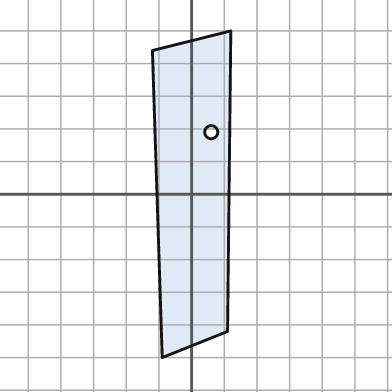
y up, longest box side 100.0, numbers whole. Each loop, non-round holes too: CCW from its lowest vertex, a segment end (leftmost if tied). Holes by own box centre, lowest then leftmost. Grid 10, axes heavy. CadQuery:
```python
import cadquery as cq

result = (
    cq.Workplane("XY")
    .moveTo(-9.0, -50.0)
    .lineTo(11.0, -42.0)
    .lineTo(12.0, 50.0)
    .lineTo(-12.0, 44.0)
    .close()
    .moveTo(6.0, 19.0)
    .circle(2.0)
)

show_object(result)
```